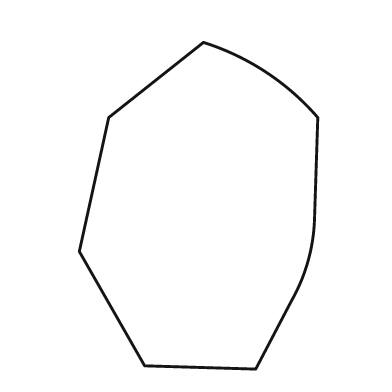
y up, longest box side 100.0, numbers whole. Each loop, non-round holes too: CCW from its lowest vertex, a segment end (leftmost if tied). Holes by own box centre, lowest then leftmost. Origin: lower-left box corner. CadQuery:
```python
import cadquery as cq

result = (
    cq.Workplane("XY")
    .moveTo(54.0, 0.0)
    .lineTo(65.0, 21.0)
    .threePointArc((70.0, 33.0), (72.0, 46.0))
    .lineTo(73.0, 77.0)
    .threePointArc((57.0, 91.0), (38.0, 100.0))
    .lineTo(9.0, 77.0)
    .lineTo(0.0, 36.0)
    .lineTo(20.0, 1.0)
    .close()
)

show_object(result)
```